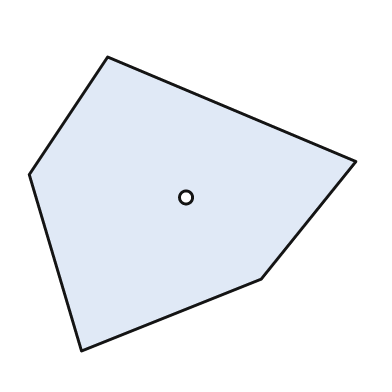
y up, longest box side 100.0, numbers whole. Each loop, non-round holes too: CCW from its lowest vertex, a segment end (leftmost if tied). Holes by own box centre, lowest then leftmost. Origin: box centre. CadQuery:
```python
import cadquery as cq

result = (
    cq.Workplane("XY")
    .moveTo(-34.0, -45.0)
    .lineTo(21.0, -23.0)
    .lineTo(50.0, 13.0)
    .lineTo(-26.0, 45.0)
    .lineTo(-50.0, 9.0)
    .close()
    .moveTo(-2.0, 2.0)
    .circle(2.0)
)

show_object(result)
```